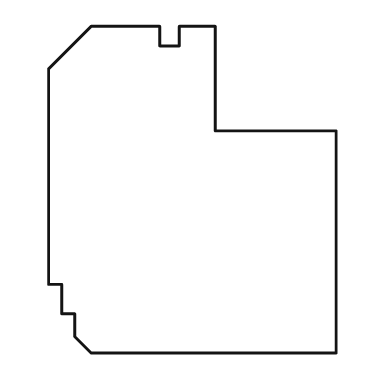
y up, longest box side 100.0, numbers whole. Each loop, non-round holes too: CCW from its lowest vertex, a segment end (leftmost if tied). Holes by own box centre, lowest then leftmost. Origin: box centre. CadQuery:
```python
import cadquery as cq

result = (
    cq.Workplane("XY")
    .moveTo(-31.0, -50.0)
    .lineTo(44.0, -50.0)
    .lineTo(44.0, 18.0)
    .lineTo(7.0, 18.0)
    .lineTo(7.0, 50.0)
    .lineTo(-4.0, 50.0)
    .lineTo(-4.0, 44.0)
    .lineTo(-10.0, 44.0)
    .lineTo(-10.0, 50.0)
    .lineTo(-31.0, 50.0)
    .lineTo(-44.0, 37.0)
    .lineTo(-44.0, -29.0)
    .lineTo(-40.0, -29.0)
    .lineTo(-40.0, -38.0)
    .lineTo(-36.0, -38.0)
    .lineTo(-36.0, -45.0)
    .close()
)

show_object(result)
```